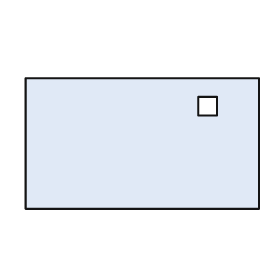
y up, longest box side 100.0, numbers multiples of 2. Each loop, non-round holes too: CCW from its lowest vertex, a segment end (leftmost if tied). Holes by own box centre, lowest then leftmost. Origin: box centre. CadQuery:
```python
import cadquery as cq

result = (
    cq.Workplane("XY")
    .moveTo(-50.0, -28.0)
    .lineTo(50.0, -28.0)
    .lineTo(50.0, 28.0)
    .lineTo(-50.0, 28.0)
    .close()
    .moveTo(24.0, 12.0)
    .lineTo(32.0, 12.0)
    .lineTo(32.0, 20.0)
    .lineTo(24.0, 20.0)
    .close()
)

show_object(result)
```